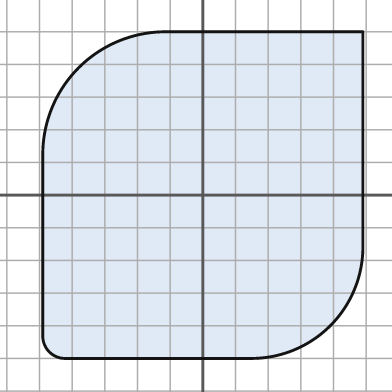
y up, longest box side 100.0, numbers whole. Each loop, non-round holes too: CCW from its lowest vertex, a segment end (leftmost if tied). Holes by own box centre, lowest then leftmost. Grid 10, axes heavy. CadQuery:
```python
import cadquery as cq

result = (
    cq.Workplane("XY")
    .moveTo(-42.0, -50.0)
    .lineTo(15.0, -50.0)
    .threePointArc((39.0, -40.0), (49.0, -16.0))
    .lineTo(49.0, 50.0)
    .lineTo(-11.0, 50.0)
    .threePointArc((-38.0, 39.0), (-49.0, 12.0))
    .lineTo(-49.0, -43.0)
    .threePointArc((-47.0, -48.0), (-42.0, -50.0))
    .close()
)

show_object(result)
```